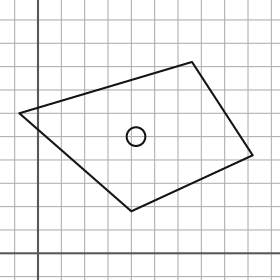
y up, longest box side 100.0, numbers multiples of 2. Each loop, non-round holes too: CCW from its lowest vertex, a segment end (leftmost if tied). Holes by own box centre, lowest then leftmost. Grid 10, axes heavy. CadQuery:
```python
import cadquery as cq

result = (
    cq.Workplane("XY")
    .moveTo(40.0, 18.0)
    .lineTo(92.0, 42.0)
    .lineTo(66.0, 82.0)
    .lineTo(-8.0, 60.0)
    .close()
    .moveTo(42.0, 50.0)
    .circle(4.0)
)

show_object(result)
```